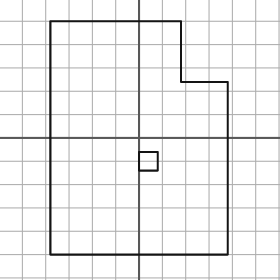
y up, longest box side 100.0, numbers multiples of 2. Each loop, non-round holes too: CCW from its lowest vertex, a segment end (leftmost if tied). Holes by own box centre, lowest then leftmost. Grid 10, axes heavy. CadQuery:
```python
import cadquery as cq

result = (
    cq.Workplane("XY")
    .moveTo(-38.0, -50.0)
    .lineTo(38.0, -50.0)
    .lineTo(38.0, 24.0)
    .lineTo(18.0, 24.0)
    .lineTo(18.0, 50.0)
    .lineTo(-38.0, 50.0)
    .close()
    .moveTo(0.0, -14.0)
    .lineTo(8.0, -14.0)
    .lineTo(8.0, -6.0)
    .lineTo(0.0, -6.0)
    .close()
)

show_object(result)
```